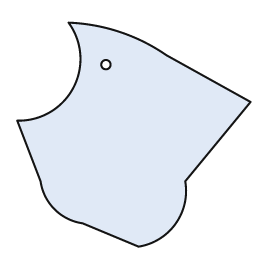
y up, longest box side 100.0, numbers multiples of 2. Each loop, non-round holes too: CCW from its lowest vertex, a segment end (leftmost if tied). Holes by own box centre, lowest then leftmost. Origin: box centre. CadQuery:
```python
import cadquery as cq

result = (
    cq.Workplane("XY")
    .moveTo(2.0, -48.0)
    .threePointArc((18.0, -38.0), (22.0, -20.0))
    .lineTo(50.0, 14.0)
    .lineTo(14.0, 34.0)
    .threePointArc((-6.0, 44.0), (-28.0, 48.0))
    .threePointArc((-26.0, 20.0), (-50.0, 6.0))
    .lineTo(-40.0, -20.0)
    .threePointArc((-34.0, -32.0), (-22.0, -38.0))
    .close()
    .moveTo(-12.0, 30.0)
    .circle(2.0)
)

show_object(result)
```